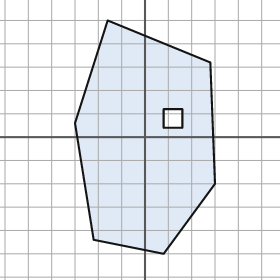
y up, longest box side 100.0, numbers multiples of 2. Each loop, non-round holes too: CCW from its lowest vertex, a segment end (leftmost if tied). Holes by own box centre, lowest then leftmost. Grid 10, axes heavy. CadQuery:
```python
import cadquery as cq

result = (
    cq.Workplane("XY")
    .moveTo(8.0, -50.0)
    .lineTo(30.0, -20.0)
    .lineTo(28.0, 32.0)
    .lineTo(-16.0, 50.0)
    .lineTo(-30.0, 6.0)
    .lineTo(-22.0, -44.0)
    .close()
    .moveTo(8.0, 4.0)
    .lineTo(16.0, 4.0)
    .lineTo(16.0, 12.0)
    .lineTo(8.0, 12.0)
    .close()
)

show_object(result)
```